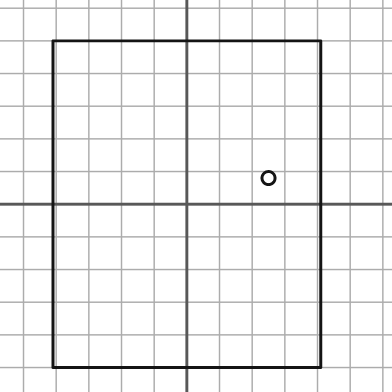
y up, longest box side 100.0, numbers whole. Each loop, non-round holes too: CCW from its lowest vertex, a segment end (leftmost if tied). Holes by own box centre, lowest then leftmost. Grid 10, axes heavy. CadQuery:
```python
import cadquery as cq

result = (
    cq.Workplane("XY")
    .moveTo(-41.0, -50.0)
    .lineTo(41.0, -50.0)
    .lineTo(41.0, 50.0)
    .lineTo(-41.0, 50.0)
    .close()
    .moveTo(25.0, 8.0)
    .circle(2.0)
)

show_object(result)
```